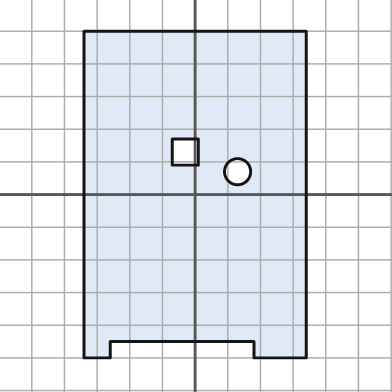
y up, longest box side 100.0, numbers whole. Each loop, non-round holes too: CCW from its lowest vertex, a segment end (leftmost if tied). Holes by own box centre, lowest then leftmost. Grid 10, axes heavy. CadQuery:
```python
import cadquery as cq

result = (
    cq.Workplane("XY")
    .moveTo(-34.0, -50.0)
    .lineTo(-26.0, -50.0)
    .lineTo(-26.0, -45.0)
    .lineTo(18.0, -45.0)
    .lineTo(18.0, -50.0)
    .lineTo(34.0, -50.0)
    .lineTo(34.0, 50.0)
    .lineTo(-34.0, 50.0)
    .close()
    .moveTo(13.0, 7.0)
    .circle(4.0)
    .moveTo(-7.0, 9.0)
    .lineTo(1.0, 9.0)
    .lineTo(1.0, 17.0)
    .lineTo(-7.0, 17.0)
    .close()
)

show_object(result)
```